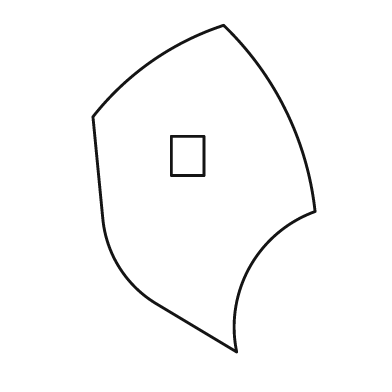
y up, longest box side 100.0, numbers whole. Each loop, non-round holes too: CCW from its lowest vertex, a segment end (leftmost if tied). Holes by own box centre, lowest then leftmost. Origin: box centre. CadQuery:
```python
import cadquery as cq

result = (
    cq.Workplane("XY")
    .moveTo(10.0, -50.0)
    .threePointArc((14.0, -24.0), (34.0, -7.0))
    .threePointArc((25.0, 24.0), (6.0, 50.0))
    .threePointArc((-16.0, 39.0), (-34.0, 22.0))
    .lineTo(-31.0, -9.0)
    .threePointArc((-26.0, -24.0), (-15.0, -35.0))
    .close()
    .moveTo(-10.0, 4.0)
    .lineTo(0.0, 4.0)
    .lineTo(0.0, 16.0)
    .lineTo(-10.0, 16.0)
    .close()
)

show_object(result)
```